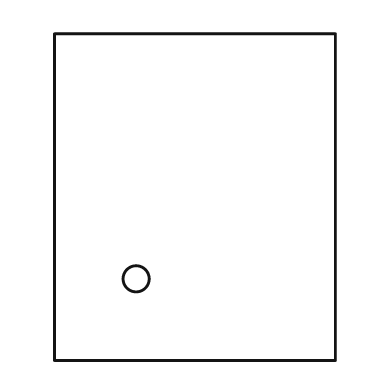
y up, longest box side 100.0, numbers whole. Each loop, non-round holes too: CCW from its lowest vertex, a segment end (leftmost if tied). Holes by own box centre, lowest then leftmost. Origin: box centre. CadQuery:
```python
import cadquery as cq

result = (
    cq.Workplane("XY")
    .moveTo(-43.0, -50.0)
    .lineTo(43.0, -50.0)
    .lineTo(43.0, 50.0)
    .lineTo(-43.0, 50.0)
    .close()
    .moveTo(-18.0, -25.0)
    .circle(4.0)
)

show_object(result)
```